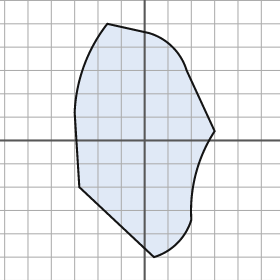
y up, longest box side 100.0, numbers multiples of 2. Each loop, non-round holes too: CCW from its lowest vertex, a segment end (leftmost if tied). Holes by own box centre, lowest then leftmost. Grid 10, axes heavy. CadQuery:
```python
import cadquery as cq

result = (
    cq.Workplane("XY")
    .moveTo(4.0, -50.0)
    .threePointArc((14.0, -44.0), (20.0, -34.0))
    .threePointArc((22.0, -14.0), (30.0, 4.0))
    .lineTo(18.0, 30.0)
    .threePointArc((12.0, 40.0), (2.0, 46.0))
    .lineTo(-16.0, 50.0)
    .threePointArc((-26.0, 32.0), (-30.0, 12.0))
    .lineTo(-28.0, -20.0)
    .close()
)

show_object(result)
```